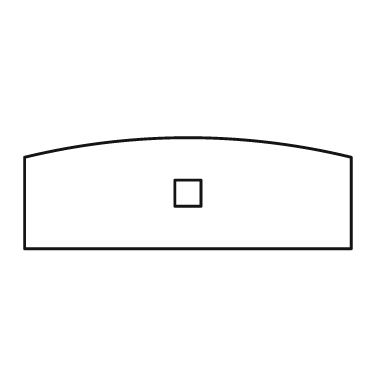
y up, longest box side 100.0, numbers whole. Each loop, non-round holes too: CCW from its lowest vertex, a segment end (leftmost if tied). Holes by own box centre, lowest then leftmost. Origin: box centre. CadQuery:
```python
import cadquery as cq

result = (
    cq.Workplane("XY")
    .moveTo(-50.0, -17.0)
    .lineTo(50.0, -17.0)
    .lineTo(50.0, 11.0)
    .threePointArc((0.0, 17.0), (-50.0, 11.0))
    .close()
    .moveTo(-4.0, -4.0)
    .lineTo(4.0, -4.0)
    .lineTo(4.0, 4.0)
    .lineTo(-4.0, 4.0)
    .close()
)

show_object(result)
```